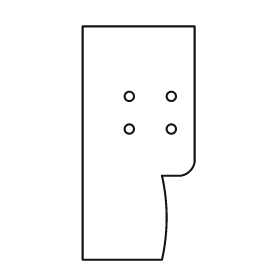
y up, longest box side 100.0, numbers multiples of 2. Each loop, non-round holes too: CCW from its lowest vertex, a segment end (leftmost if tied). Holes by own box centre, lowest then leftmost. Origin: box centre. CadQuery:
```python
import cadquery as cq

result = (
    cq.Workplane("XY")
    .moveTo(-24.0, -50.0)
    .lineTo(10.0, -50.0)
    .threePointArc((12.0, -32.0), (10.0, -14.0))
    .lineTo(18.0, -14.0)
    .threePointArc((22.0, -12.0), (24.0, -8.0))
    .lineTo(24.0, 50.0)
    .lineTo(-24.0, 50.0)
    .close()
    .moveTo(-4.0, 6.0)
    .circle(2.0)
    .moveTo(14.0, 6.0)
    .circle(2.0)
    .moveTo(-4.0, 20.0)
    .circle(2.0)
    .moveTo(14.0, 20.0)
    .circle(2.0)
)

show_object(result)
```